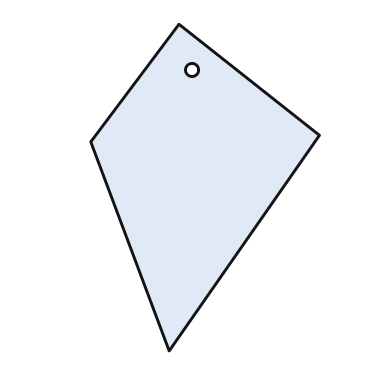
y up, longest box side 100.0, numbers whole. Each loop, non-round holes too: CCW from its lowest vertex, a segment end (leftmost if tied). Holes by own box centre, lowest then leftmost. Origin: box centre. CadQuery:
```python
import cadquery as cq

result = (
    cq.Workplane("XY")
    .moveTo(-11.0, -50.0)
    .lineTo(35.0, 16.0)
    .lineTo(-8.0, 50.0)
    .lineTo(-35.0, 14.0)
    .close()
    .moveTo(-4.0, 36.0)
    .circle(2.0)
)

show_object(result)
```